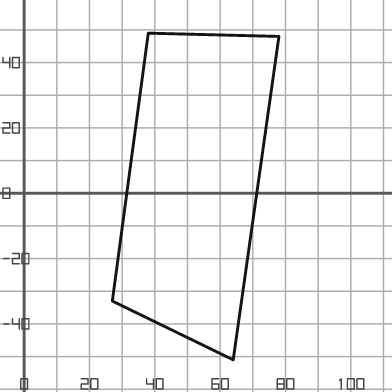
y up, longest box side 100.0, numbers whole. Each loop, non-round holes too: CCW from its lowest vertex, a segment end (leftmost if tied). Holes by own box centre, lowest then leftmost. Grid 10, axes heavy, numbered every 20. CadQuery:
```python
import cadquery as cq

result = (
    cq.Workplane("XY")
    .moveTo(64.0, -51.0)
    .lineTo(78.0, 48.0)
    .lineTo(38.0, 49.0)
    .lineTo(27.0, -33.0)
    .close()
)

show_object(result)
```